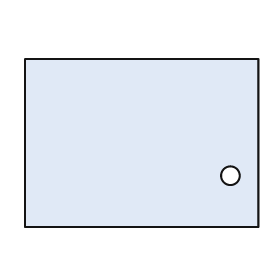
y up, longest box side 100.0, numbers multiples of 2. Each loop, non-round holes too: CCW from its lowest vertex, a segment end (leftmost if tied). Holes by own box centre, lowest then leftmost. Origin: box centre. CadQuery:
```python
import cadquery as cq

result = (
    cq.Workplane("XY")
    .moveTo(-50.0, -36.0)
    .lineTo(50.0, -36.0)
    .lineTo(50.0, 36.0)
    .lineTo(-50.0, 36.0)
    .close()
    .moveTo(38.0, -14.0)
    .circle(4.0)
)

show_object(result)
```